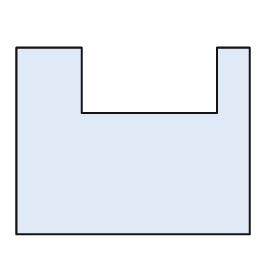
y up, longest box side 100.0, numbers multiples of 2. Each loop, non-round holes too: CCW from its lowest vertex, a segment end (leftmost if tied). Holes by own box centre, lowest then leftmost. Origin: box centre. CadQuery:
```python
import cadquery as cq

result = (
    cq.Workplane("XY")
    .moveTo(-50.0, -40.0)
    .lineTo(50.0, -40.0)
    .lineTo(50.0, 40.0)
    .lineTo(36.0, 40.0)
    .lineTo(36.0, 12.0)
    .lineTo(-22.0, 12.0)
    .lineTo(-22.0, 40.0)
    .lineTo(-50.0, 40.0)
    .close()
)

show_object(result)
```